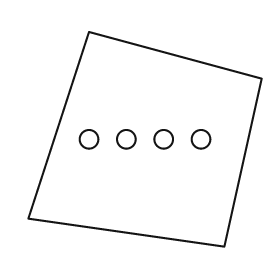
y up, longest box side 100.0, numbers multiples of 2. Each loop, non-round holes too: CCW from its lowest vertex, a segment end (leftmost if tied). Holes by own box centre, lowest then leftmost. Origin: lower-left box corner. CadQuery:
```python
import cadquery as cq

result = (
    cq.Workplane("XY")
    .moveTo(84.0, 0.0)
    .lineTo(100.0, 72.0)
    .lineTo(26.0, 92.0)
    .lineTo(0.0, 12.0)
    .close()
    .moveTo(26.0, 46.0)
    .circle(4.0)
    .moveTo(42.0, 46.0)
    .circle(4.0)
    .moveTo(58.0, 46.0)
    .circle(4.0)
    .moveTo(74.0, 46.0)
    .circle(4.0)
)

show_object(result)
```